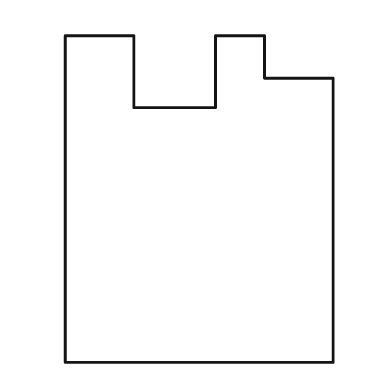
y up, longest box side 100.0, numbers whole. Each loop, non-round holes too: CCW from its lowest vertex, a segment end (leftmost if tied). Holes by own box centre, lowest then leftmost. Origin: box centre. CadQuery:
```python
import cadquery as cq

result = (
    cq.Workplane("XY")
    .moveTo(-41.0, -50.0)
    .lineTo(41.0, -50.0)
    .lineTo(41.0, 37.0)
    .lineTo(20.0, 37.0)
    .lineTo(20.0, 50.0)
    .lineTo(5.0, 50.0)
    .lineTo(5.0, 28.0)
    .lineTo(-20.0, 28.0)
    .lineTo(-20.0, 50.0)
    .lineTo(-41.0, 50.0)
    .close()
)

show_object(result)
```